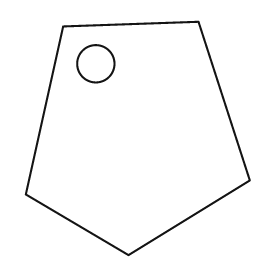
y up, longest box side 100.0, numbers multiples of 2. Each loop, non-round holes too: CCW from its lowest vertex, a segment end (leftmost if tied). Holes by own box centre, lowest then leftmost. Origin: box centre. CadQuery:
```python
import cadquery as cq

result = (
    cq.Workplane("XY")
    .moveTo(-4.0, -50.0)
    .lineTo(48.0, -18.0)
    .lineTo(26.0, 50.0)
    .lineTo(-32.0, 48.0)
    .lineTo(-48.0, -24.0)
    .close()
    .moveTo(-18.0, 32.0)
    .circle(8.0)
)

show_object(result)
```